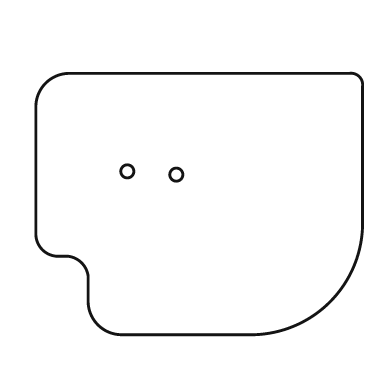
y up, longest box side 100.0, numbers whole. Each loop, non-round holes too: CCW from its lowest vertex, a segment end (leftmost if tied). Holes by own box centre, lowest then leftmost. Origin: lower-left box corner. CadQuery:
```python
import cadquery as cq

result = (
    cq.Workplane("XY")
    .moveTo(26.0, 0.0)
    .lineTo(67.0, 0.0)
    .threePointArc((90.0, 10.0), (100.0, 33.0))
    .lineTo(100.0, 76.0)
    .threePointArc((99.0, 79.0), (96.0, 80.0))
    .lineTo(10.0, 80.0)
    .threePointArc((3.0, 77.0), (0.0, 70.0))
    .lineTo(0.0, 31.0)
    .threePointArc((2.0, 26.0), (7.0, 24.0))
    .lineTo(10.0, 24.0)
    .threePointArc((14.0, 22.0), (16.0, 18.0))
    .lineTo(16.0, 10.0)
    .threePointArc((19.0, 3.0), (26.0, 0.0))
    .close()
    .moveTo(43.0, 49.0)
    .circle(2.0)
    .moveTo(28.0, 50.0)
    .circle(2.0)
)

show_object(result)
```